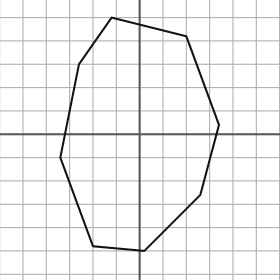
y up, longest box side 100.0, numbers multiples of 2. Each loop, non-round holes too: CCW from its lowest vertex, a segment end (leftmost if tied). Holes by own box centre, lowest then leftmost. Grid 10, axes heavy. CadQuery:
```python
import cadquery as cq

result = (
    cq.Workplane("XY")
    .moveTo(2.0, -50.0)
    .lineTo(26.0, -26.0)
    .lineTo(34.0, 4.0)
    .lineTo(20.0, 42.0)
    .lineTo(-12.0, 50.0)
    .lineTo(-26.0, 30.0)
    .lineTo(-34.0, -10.0)
    .lineTo(-20.0, -48.0)
    .close()
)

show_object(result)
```